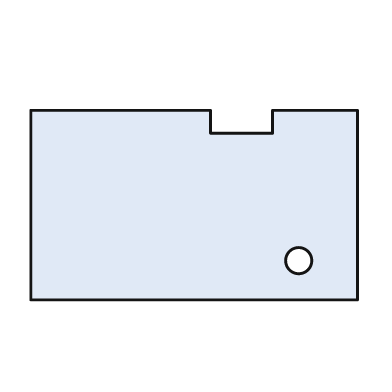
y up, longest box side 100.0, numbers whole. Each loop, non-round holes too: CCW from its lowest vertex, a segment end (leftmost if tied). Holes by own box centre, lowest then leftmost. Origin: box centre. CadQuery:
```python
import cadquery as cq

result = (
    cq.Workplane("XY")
    .moveTo(-50.0, -29.0)
    .lineTo(50.0, -29.0)
    .lineTo(50.0, 29.0)
    .lineTo(24.0, 29.0)
    .lineTo(24.0, 22.0)
    .lineTo(5.0, 22.0)
    .lineTo(5.0, 29.0)
    .lineTo(-50.0, 29.0)
    .close()
    .moveTo(32.0, -17.0)
    .circle(4.0)
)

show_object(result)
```